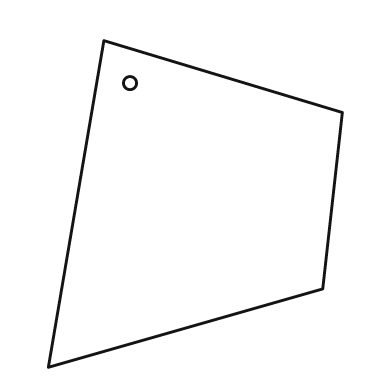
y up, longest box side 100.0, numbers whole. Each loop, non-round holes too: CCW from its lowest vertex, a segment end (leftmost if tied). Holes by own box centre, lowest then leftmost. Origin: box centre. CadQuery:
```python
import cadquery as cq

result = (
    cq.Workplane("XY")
    .moveTo(-45.0, -50.0)
    .lineTo(39.0, -26.0)
    .lineTo(45.0, 28.0)
    .lineTo(-28.0, 50.0)
    .close()
    .moveTo(-20.0, 37.0)
    .circle(2.0)
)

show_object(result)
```